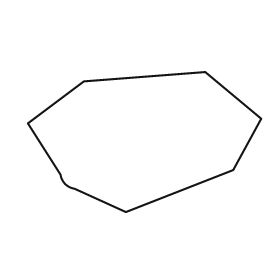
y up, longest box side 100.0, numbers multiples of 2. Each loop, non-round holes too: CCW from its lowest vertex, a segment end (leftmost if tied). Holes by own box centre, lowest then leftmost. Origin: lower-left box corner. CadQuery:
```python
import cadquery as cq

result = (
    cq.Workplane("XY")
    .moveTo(42.0, 0.0)
    .lineTo(88.0, 18.0)
    .lineTo(100.0, 40.0)
    .lineTo(76.0, 60.0)
    .lineTo(24.0, 56.0)
    .lineTo(0.0, 38.0)
    .lineTo(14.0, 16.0)
    .threePointArc((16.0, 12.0), (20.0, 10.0))
    .close()
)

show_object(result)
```